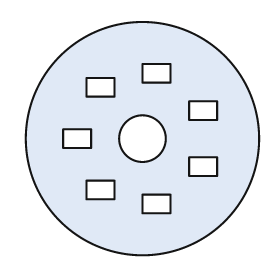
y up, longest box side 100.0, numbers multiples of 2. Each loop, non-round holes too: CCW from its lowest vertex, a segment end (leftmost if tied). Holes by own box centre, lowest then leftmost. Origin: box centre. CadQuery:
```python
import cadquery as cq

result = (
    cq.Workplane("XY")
    .moveTo(0.0, 0.0)
    .circle(50.0)
    .moveTo(0.0, -32.0)
    .lineTo(12.0, -32.0)
    .lineTo(12.0, -24.0)
    .lineTo(0.0, -24.0)
    .close()
    .moveTo(-24.0, -26.0)
    .lineTo(-12.0, -26.0)
    .lineTo(-12.0, -18.0)
    .lineTo(-24.0, -18.0)
    .close()
    .moveTo(20.0, -16.0)
    .lineTo(32.0, -16.0)
    .lineTo(32.0, -8.0)
    .lineTo(20.0, -8.0)
    .close()
    .moveTo(-34.0, -4.0)
    .lineTo(-22.0, -4.0)
    .lineTo(-22.0, 4.0)
    .lineTo(-34.0, 4.0)
    .close()
    .moveTo(0.0, 0.0)
    .circle(10.0)
    .moveTo(20.0, 8.0)
    .lineTo(32.0, 8.0)
    .lineTo(32.0, 16.0)
    .lineTo(20.0, 16.0)
    .close()
    .moveTo(-24.0, 18.0)
    .lineTo(-12.0, 18.0)
    .lineTo(-12.0, 26.0)
    .lineTo(-24.0, 26.0)
    .close()
    .moveTo(0.0, 24.0)
    .lineTo(12.0, 24.0)
    .lineTo(12.0, 32.0)
    .lineTo(0.0, 32.0)
    .close()
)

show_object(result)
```